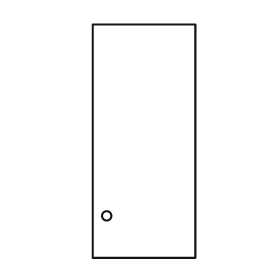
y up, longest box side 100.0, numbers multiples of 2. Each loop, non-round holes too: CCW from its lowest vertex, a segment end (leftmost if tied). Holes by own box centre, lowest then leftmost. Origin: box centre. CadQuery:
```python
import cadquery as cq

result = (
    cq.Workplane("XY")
    .moveTo(-22.0, -50.0)
    .lineTo(22.0, -50.0)
    .lineTo(22.0, 50.0)
    .lineTo(-22.0, 50.0)
    .close()
    .moveTo(-16.0, -32.0)
    .circle(2.0)
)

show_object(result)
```